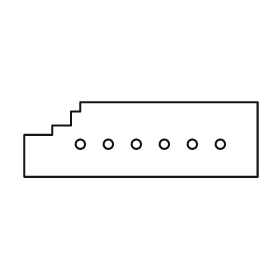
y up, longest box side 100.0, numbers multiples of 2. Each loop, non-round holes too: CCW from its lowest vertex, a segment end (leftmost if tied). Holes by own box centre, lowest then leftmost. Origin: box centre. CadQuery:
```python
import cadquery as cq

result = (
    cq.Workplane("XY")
    .moveTo(-50.0, -16.0)
    .lineTo(50.0, -16.0)
    .lineTo(50.0, 16.0)
    .lineTo(-26.0, 16.0)
    .lineTo(-26.0, 12.0)
    .lineTo(-30.0, 12.0)
    .lineTo(-30.0, 6.0)
    .lineTo(-38.0, 6.0)
    .lineTo(-38.0, 2.0)
    .lineTo(-50.0, 2.0)
    .close()
    .moveTo(-26.0, -2.0)
    .circle(2.0)
    .moveTo(-14.0, -2.0)
    .circle(2.0)
    .moveTo(-2.0, -2.0)
    .circle(2.0)
    .moveTo(10.0, -2.0)
    .circle(2.0)
    .moveTo(22.0, -2.0)
    .circle(2.0)
    .moveTo(34.0, -2.0)
    .circle(2.0)
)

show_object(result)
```